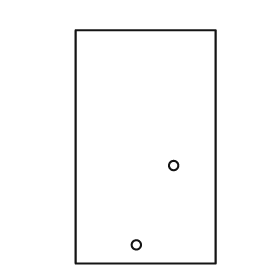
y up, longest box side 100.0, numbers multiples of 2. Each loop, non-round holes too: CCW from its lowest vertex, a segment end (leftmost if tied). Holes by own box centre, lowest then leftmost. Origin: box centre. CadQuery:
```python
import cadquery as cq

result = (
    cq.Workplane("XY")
    .moveTo(-30.0, -50.0)
    .lineTo(30.0, -50.0)
    .lineTo(30.0, 50.0)
    .lineTo(-30.0, 50.0)
    .close()
    .moveTo(-4.0, -42.0)
    .circle(2.0)
    .moveTo(12.0, -8.0)
    .circle(2.0)
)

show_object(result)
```